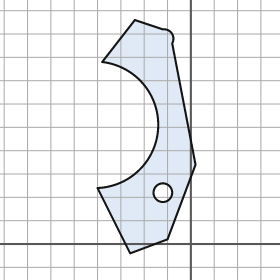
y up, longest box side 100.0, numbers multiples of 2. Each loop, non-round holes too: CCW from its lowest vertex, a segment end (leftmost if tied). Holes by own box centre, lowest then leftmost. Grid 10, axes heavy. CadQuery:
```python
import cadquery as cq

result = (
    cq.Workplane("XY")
    .moveTo(-26.0, -4.0)
    .lineTo(-10.0, 2.0)
    .lineTo(2.0, 34.0)
    .lineTo(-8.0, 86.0)
    .threePointArc((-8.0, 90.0), (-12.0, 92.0))
    .lineTo(-24.0, 96.0)
    .lineTo(-38.0, 78.0)
    .threePointArc((-14.0, 50.0), (-40.0, 24.0))
    .close()
    .moveTo(-12.0, 22.0)
    .circle(4.0)
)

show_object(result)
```